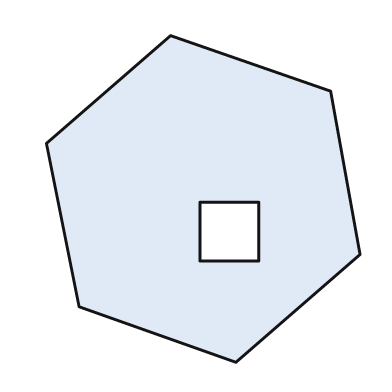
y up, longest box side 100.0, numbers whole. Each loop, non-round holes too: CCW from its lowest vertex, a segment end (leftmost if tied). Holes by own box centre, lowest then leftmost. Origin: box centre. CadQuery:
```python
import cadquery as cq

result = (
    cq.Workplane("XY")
    .moveTo(10.0, -50.0)
    .lineTo(48.0, -17.0)
    .lineTo(39.0, 33.0)
    .lineTo(-10.0, 50.0)
    .lineTo(-48.0, 17.0)
    .lineTo(-38.0, -33.0)
    .close()
    .moveTo(-1.0, -19.0)
    .lineTo(17.0, -19.0)
    .lineTo(17.0, -1.0)
    .lineTo(-1.0, -1.0)
    .close()
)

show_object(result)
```